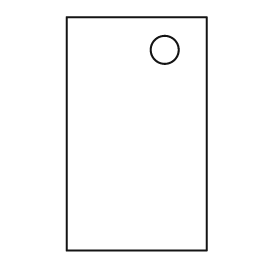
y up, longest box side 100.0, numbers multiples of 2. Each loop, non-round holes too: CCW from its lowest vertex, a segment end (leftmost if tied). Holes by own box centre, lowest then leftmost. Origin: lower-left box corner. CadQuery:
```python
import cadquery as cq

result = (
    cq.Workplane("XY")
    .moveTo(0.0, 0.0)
    .lineTo(60.0, 0.0)
    .lineTo(60.0, 100.0)
    .lineTo(0.0, 100.0)
    .close()
    .moveTo(42.0, 86.0)
    .circle(6.0)
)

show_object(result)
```